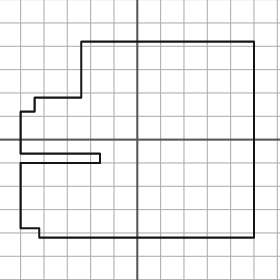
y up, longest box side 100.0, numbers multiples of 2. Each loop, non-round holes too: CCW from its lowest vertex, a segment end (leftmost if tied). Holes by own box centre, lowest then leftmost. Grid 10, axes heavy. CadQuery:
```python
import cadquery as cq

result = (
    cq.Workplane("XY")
    .moveTo(-42.0, -42.0)
    .lineTo(50.0, -42.0)
    .lineTo(50.0, 42.0)
    .lineTo(-24.0, 42.0)
    .lineTo(-24.0, 18.0)
    .lineTo(-44.0, 18.0)
    .lineTo(-44.0, 12.0)
    .lineTo(-50.0, 12.0)
    .lineTo(-50.0, -6.0)
    .lineTo(-16.0, -6.0)
    .lineTo(-16.0, -10.0)
    .lineTo(-50.0, -10.0)
    .lineTo(-50.0, -38.0)
    .lineTo(-42.0, -38.0)
    .close()
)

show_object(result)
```